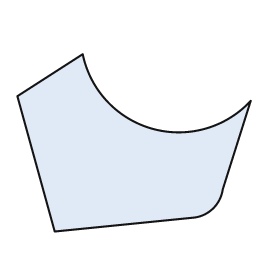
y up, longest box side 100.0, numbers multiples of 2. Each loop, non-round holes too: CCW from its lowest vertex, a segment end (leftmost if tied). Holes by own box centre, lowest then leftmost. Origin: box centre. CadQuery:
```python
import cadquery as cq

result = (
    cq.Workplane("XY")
    .moveTo(-34.0, -38.0)
    .lineTo(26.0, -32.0)
    .threePointArc((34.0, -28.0), (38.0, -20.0))
    .lineTo(50.0, 18.0)
    .threePointArc((8.0, 6.0), (-22.0, 38.0))
    .lineTo(-50.0, 20.0)
    .close()
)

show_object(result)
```